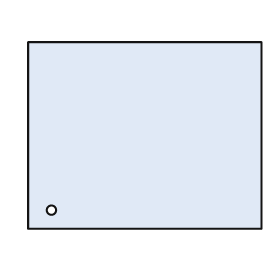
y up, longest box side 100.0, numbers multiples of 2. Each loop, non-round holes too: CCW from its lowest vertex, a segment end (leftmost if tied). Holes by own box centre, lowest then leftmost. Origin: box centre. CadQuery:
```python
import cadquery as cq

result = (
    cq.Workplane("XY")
    .moveTo(-50.0, -40.0)
    .lineTo(50.0, -40.0)
    .lineTo(50.0, 40.0)
    .lineTo(-50.0, 40.0)
    .close()
    .moveTo(-40.0, -32.0)
    .circle(2.0)
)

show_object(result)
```